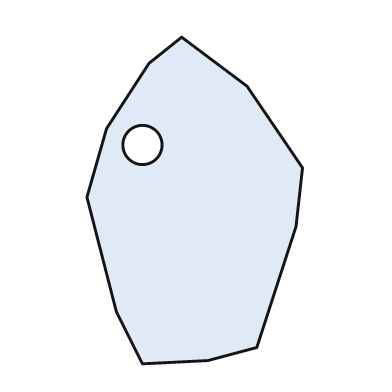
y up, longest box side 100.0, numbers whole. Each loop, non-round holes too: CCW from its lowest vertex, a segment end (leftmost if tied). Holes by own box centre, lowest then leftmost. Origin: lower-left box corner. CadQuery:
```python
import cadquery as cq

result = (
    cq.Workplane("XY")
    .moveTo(17.0, 0.0)
    .lineTo(37.0, 1.0)
    .lineTo(52.0, 5.0)
    .lineTo(64.0, 42.0)
    .lineTo(66.0, 60.0)
    .lineTo(49.0, 85.0)
    .lineTo(29.0, 100.0)
    .lineTo(19.0, 92.0)
    .lineTo(6.0, 72.0)
    .lineTo(0.0, 51.0)
    .lineTo(9.0, 16.0)
    .close()
    .moveTo(17.0, 67.0)
    .circle(6.0)
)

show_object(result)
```